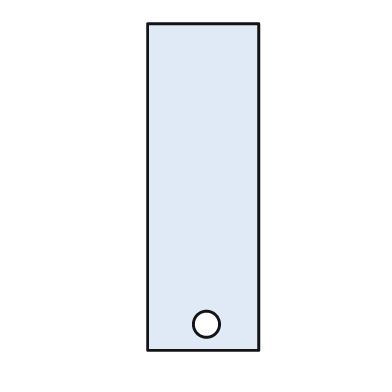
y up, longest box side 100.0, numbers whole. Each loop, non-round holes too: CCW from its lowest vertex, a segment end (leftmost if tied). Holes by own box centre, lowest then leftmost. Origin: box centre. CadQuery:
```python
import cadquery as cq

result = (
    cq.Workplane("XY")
    .moveTo(-17.0, -50.0)
    .lineTo(17.0, -50.0)
    .lineTo(17.0, 50.0)
    .lineTo(-17.0, 50.0)
    .close()
    .moveTo(1.0, -42.0)
    .circle(4.0)
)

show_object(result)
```